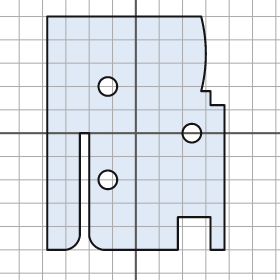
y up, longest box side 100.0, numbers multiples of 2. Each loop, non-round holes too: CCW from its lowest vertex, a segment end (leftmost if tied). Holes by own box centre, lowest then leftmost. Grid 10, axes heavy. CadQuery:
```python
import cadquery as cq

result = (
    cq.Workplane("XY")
    .moveTo(-38.0, -50.0)
    .lineTo(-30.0, -50.0)
    .threePointArc((-26.0, -48.0), (-24.0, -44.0))
    .lineTo(-24.0, 0.0)
    .lineTo(-20.0, 0.0)
    .lineTo(-20.0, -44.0)
    .threePointArc((-18.0, -48.0), (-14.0, -50.0))
    .lineTo(18.0, -50.0)
    .lineTo(18.0, -36.0)
    .lineTo(32.0, -36.0)
    .lineTo(32.0, -50.0)
    .lineTo(38.0, -50.0)
    .lineTo(38.0, 12.0)
    .lineTo(32.0, 12.0)
    .lineTo(32.0, 18.0)
    .lineTo(28.0, 18.0)
    .threePointArc((30.0, 34.0), (28.0, 50.0))
    .lineTo(-38.0, 50.0)
    .close()
    .moveTo(-12.0, -20.0)
    .circle(4.0)
    .moveTo(24.0, 0.0)
    .circle(4.0)
    .moveTo(-12.0, 20.0)
    .circle(4.0)
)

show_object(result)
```